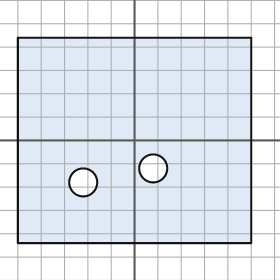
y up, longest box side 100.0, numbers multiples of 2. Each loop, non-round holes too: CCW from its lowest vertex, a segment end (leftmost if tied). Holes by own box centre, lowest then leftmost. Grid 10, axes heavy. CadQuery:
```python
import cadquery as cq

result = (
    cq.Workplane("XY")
    .moveTo(-50.0, -44.0)
    .lineTo(50.0, -44.0)
    .lineTo(50.0, 44.0)
    .lineTo(-50.0, 44.0)
    .close()
    .moveTo(-22.0, -18.0)
    .circle(6.0)
    .moveTo(8.0, -12.0)
    .circle(6.0)
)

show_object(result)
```